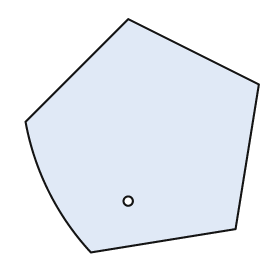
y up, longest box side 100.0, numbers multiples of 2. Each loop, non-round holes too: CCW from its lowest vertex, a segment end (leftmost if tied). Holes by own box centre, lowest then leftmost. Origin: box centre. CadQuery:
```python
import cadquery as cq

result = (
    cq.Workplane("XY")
    .moveTo(-22.0, -50.0)
    .lineTo(40.0, -40.0)
    .lineTo(50.0, 22.0)
    .lineTo(-6.0, 50.0)
    .lineTo(-50.0, 6.0)
    .threePointArc((-40.0, -24.0), (-22.0, -50.0))
    .close()
    .moveTo(-6.0, -28.0)
    .circle(2.0)
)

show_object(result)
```